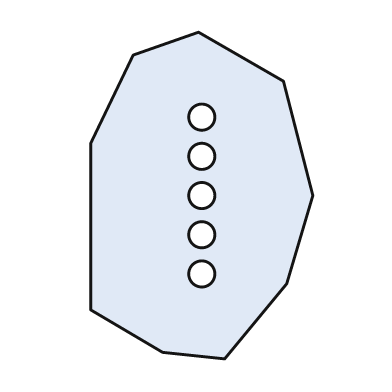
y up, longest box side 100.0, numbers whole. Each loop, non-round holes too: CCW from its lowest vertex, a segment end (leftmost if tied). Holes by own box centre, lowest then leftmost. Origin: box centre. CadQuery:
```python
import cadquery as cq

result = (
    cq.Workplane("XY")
    .moveTo(7.0, -50.0)
    .lineTo(26.0, -27.0)
    .lineTo(34.0, 0.0)
    .lineTo(25.0, 35.0)
    .lineTo(-1.0, 50.0)
    .lineTo(-21.0, 43.0)
    .lineTo(-34.0, 16.0)
    .lineTo(-34.0, -35.0)
    .lineTo(-12.0, -48.0)
    .close()
    .moveTo(0.0, -24.0)
    .circle(4.0)
    .moveTo(0.0, -12.0)
    .circle(4.0)
    .moveTo(0.0, 0.0)
    .circle(4.0)
    .moveTo(0.0, 12.0)
    .circle(4.0)
    .moveTo(0.0, 24.0)
    .circle(4.0)
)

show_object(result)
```